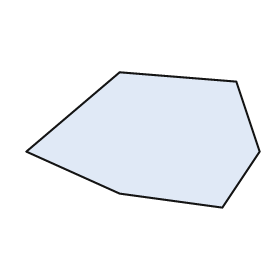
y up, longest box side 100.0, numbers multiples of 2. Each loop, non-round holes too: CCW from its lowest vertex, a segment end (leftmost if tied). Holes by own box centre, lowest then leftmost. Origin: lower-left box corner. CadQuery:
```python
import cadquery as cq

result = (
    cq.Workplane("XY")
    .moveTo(84.0, 0.0)
    .lineTo(100.0, 24.0)
    .lineTo(90.0, 54.0)
    .lineTo(40.0, 58.0)
    .lineTo(0.0, 24.0)
    .lineTo(40.0, 6.0)
    .close()
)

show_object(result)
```